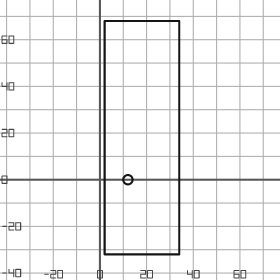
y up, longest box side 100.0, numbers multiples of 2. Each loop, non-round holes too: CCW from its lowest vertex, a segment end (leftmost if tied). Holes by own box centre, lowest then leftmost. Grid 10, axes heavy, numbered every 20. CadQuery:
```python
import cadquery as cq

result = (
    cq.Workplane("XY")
    .moveTo(2.0, -32.0)
    .lineTo(34.0, -32.0)
    .lineTo(34.0, 68.0)
    .lineTo(2.0, 68.0)
    .close()
    .moveTo(12.0, 0.0)
    .circle(2.0)
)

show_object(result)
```